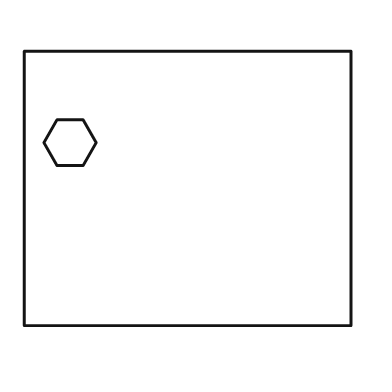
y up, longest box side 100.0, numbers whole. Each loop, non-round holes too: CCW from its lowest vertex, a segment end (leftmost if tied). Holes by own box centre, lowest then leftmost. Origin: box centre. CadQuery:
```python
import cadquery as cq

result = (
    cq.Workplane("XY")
    .moveTo(-50.0, -42.0)
    .lineTo(50.0, -42.0)
    .lineTo(50.0, 42.0)
    .lineTo(-50.0, 42.0)
    .close()
    .moveTo(-40.0, 7.0)
    .lineTo(-32.0, 7.0)
    .lineTo(-28.0, 14.0)
    .lineTo(-32.0, 21.0)
    .lineTo(-40.0, 21.0)
    .lineTo(-44.0, 14.0)
    .close()
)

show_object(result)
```